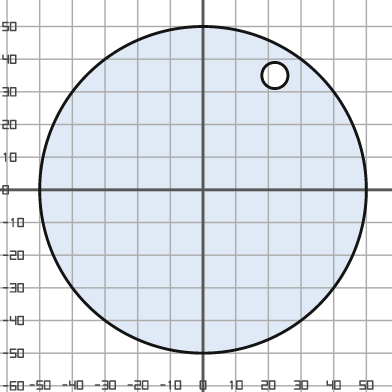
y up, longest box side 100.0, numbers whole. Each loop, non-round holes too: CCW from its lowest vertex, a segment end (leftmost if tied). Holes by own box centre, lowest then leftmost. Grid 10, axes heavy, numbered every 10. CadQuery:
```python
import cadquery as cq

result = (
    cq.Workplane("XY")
    .moveTo(0.0, 0.0)
    .circle(50.0)
    .moveTo(22.0, 35.0)
    .circle(4.0)
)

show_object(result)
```